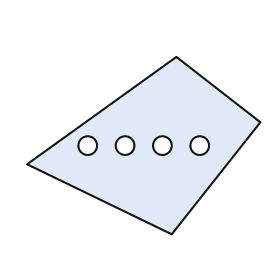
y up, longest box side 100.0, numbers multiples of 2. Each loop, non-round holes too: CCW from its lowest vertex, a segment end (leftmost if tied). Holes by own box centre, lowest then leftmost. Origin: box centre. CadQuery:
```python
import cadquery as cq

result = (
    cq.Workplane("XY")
    .moveTo(12.0, -38.0)
    .lineTo(50.0, 10.0)
    .lineTo(14.0, 38.0)
    .lineTo(-50.0, -8.0)
    .close()
    .moveTo(-24.0, 0.0)
    .circle(4.0)
    .moveTo(-8.0, 0.0)
    .circle(4.0)
    .moveTo(8.0, 0.0)
    .circle(4.0)
    .moveTo(24.0, 0.0)
    .circle(4.0)
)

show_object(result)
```